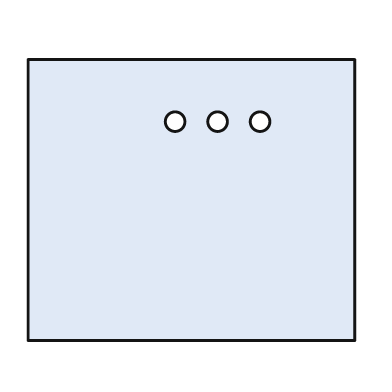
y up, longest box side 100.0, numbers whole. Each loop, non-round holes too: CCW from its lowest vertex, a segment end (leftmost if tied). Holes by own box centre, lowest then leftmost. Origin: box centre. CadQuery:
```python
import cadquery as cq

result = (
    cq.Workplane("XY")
    .moveTo(-50.0, -43.0)
    .lineTo(50.0, -43.0)
    .lineTo(50.0, 43.0)
    .lineTo(-50.0, 43.0)
    .close()
    .moveTo(-5.0, 24.0)
    .circle(3.0)
    .moveTo(8.0, 24.0)
    .circle(3.0)
    .moveTo(21.0, 24.0)
    .circle(3.0)
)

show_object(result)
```